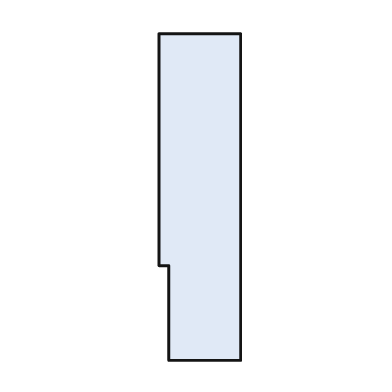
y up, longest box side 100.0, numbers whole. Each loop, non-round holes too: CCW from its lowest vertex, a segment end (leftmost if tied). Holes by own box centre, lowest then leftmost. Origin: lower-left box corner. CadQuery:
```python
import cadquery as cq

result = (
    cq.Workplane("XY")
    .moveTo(3.0, 0.0)
    .lineTo(25.0, 0.0)
    .lineTo(25.0, 100.0)
    .lineTo(0.0, 100.0)
    .lineTo(0.0, 29.0)
    .lineTo(3.0, 29.0)
    .close()
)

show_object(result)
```